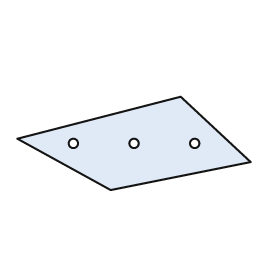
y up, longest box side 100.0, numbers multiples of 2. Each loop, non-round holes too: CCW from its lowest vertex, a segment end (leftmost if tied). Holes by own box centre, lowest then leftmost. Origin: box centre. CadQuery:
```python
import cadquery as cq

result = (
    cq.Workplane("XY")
    .moveTo(-10.0, -20.0)
    .lineTo(50.0, -8.0)
    .lineTo(20.0, 20.0)
    .lineTo(-50.0, 2.0)
    .close()
    .moveTo(-26.0, 0.0)
    .circle(2.0)
    .moveTo(0.0, 0.0)
    .circle(2.0)
    .moveTo(26.0, 0.0)
    .circle(2.0)
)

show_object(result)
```